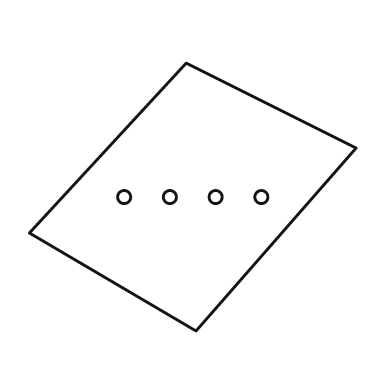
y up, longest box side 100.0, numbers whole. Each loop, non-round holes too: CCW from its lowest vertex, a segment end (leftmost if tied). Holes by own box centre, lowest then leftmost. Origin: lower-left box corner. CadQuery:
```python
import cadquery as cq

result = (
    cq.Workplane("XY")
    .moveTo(51.0, 0.0)
    .lineTo(100.0, 56.0)
    .lineTo(48.0, 82.0)
    .lineTo(0.0, 30.0)
    .close()
    .moveTo(29.0, 41.0)
    .circle(2.0)
    .moveTo(43.0, 41.0)
    .circle(2.0)
    .moveTo(57.0, 41.0)
    .circle(2.0)
    .moveTo(71.0, 41.0)
    .circle(2.0)
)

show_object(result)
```